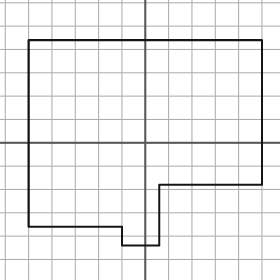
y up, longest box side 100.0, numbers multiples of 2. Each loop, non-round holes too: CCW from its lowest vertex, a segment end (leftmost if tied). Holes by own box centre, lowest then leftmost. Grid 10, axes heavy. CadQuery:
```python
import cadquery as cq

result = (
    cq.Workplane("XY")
    .moveTo(-10.0, -44.0)
    .lineTo(6.0, -44.0)
    .lineTo(6.0, -18.0)
    .lineTo(50.0, -18.0)
    .lineTo(50.0, 44.0)
    .lineTo(-50.0, 44.0)
    .lineTo(-50.0, -36.0)
    .lineTo(-10.0, -36.0)
    .close()
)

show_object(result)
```